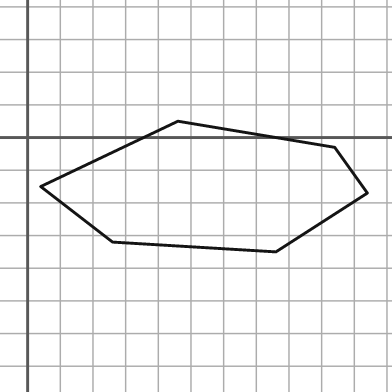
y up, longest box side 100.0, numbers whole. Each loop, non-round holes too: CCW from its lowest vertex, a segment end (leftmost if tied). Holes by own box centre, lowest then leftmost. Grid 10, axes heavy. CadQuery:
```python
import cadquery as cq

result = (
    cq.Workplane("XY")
    .moveTo(76.0, -35.0)
    .lineTo(104.0, -17.0)
    .lineTo(94.0, -3.0)
    .lineTo(46.0, 5.0)
    .lineTo(4.0, -15.0)
    .lineTo(26.0, -32.0)
    .close()
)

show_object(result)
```